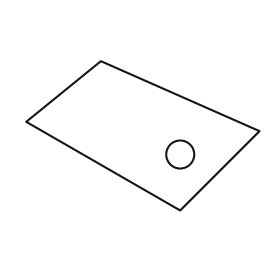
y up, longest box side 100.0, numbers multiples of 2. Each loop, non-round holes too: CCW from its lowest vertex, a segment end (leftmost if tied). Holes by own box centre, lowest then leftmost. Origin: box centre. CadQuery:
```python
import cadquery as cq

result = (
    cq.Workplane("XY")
    .moveTo(16.0, -32.0)
    .lineTo(50.0, 2.0)
    .lineTo(-18.0, 32.0)
    .lineTo(-50.0, 6.0)
    .close()
    .moveTo(16.0, -8.0)
    .circle(6.0)
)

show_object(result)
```